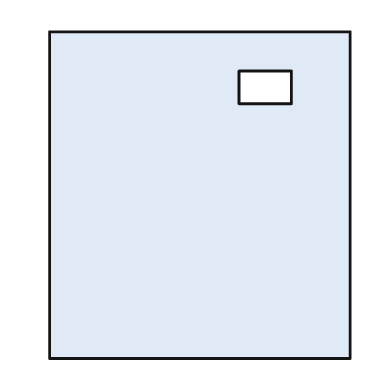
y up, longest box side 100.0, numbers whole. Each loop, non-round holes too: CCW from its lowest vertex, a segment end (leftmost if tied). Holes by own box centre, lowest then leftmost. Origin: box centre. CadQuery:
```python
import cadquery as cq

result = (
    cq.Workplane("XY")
    .moveTo(-46.0, -50.0)
    .lineTo(46.0, -50.0)
    .lineTo(46.0, 50.0)
    .lineTo(-46.0, 50.0)
    .close()
    .moveTo(12.0, 28.0)
    .lineTo(28.0, 28.0)
    .lineTo(28.0, 38.0)
    .lineTo(12.0, 38.0)
    .close()
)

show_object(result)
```